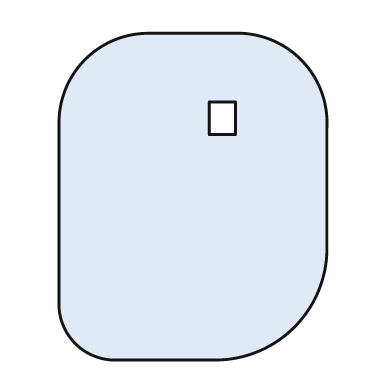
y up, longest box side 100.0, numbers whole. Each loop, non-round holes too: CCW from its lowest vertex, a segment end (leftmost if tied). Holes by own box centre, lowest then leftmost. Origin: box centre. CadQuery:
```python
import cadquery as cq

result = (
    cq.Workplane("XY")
    .moveTo(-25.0, -50.0)
    .lineTo(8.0, -50.0)
    .threePointArc((31.0, -40.0), (41.0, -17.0))
    .lineTo(41.0, 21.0)
    .threePointArc((33.0, 42.0), (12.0, 50.0))
    .lineTo(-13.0, 50.0)
    .threePointArc((-33.0, 42.0), (-41.0, 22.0))
    .lineTo(-41.0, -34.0)
    .threePointArc((-36.0, -45.0), (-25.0, -50.0))
    .close()
    .moveTo(5.0, 19.0)
    .lineTo(13.0, 19.0)
    .lineTo(13.0, 29.0)
    .lineTo(5.0, 29.0)
    .close()
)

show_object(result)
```